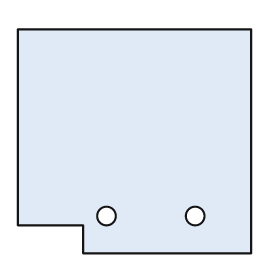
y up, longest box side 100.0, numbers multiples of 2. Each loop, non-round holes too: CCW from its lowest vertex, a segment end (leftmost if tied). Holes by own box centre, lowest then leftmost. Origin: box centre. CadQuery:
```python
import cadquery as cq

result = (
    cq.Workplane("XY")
    .moveTo(-22.0, -48.0)
    .lineTo(50.0, -48.0)
    .lineTo(50.0, 48.0)
    .lineTo(-50.0, 48.0)
    .lineTo(-50.0, -36.0)
    .lineTo(-22.0, -36.0)
    .close()
    .moveTo(-12.0, -32.0)
    .circle(4.0)
    .moveTo(26.0, -32.0)
    .circle(4.0)
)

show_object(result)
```